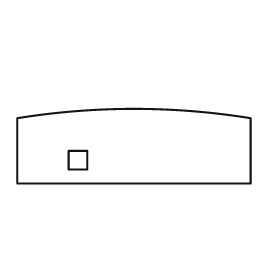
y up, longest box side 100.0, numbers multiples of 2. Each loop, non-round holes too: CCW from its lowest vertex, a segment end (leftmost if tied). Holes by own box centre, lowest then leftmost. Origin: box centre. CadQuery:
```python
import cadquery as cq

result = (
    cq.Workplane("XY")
    .moveTo(-50.0, -16.0)
    .lineTo(50.0, -16.0)
    .lineTo(50.0, 12.0)
    .threePointArc((0.0, 16.0), (-50.0, 12.0))
    .close()
    .moveTo(-28.0, -10.0)
    .lineTo(-20.0, -10.0)
    .lineTo(-20.0, -2.0)
    .lineTo(-28.0, -2.0)
    .close()
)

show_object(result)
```